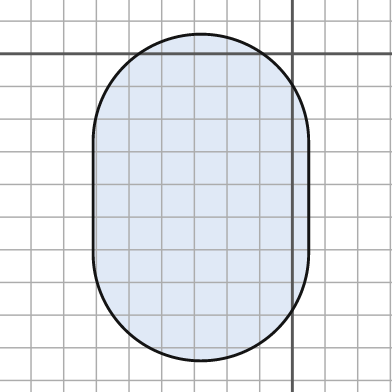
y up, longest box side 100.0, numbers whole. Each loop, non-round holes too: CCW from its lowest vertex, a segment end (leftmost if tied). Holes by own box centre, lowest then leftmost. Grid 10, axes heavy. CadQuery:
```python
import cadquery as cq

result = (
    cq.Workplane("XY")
    .moveTo(-61.0, -61.0)
    .threePointArc((-28.0, -94.0), (5.0, -61.0))
    .lineTo(5.0, -27.0)
    .threePointArc((-28.0, 6.0), (-61.0, -27.0))
    .close()
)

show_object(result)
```